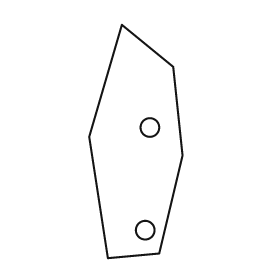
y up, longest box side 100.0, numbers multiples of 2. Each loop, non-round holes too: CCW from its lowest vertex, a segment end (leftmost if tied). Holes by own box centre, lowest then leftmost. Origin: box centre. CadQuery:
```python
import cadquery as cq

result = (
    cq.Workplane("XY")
    .moveTo(-12.0, -50.0)
    .lineTo(10.0, -48.0)
    .lineTo(20.0, -6.0)
    .lineTo(16.0, 32.0)
    .lineTo(-6.0, 50.0)
    .lineTo(-20.0, 2.0)
    .close()
    .moveTo(4.0, -38.0)
    .circle(4.0)
    .moveTo(6.0, 6.0)
    .circle(4.0)
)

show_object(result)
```